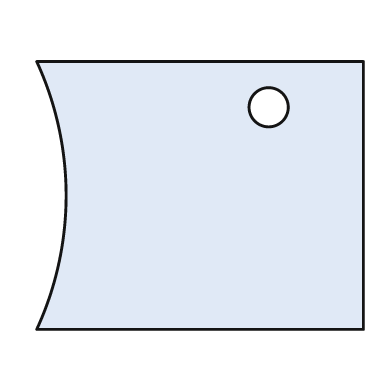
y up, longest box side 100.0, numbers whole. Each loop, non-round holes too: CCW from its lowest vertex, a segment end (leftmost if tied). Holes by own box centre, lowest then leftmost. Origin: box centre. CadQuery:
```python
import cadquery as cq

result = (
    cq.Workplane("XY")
    .moveTo(-50.0, -41.0)
    .lineTo(50.0, -41.0)
    .lineTo(50.0, 41.0)
    .lineTo(-50.0, 41.0)
    .threePointArc((-41.0, 0.0), (-50.0, -41.0))
    .close()
    .moveTo(21.0, 27.0)
    .circle(6.0)
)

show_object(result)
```